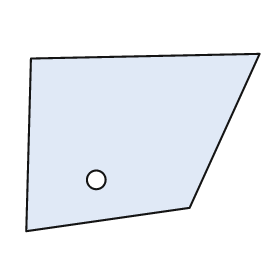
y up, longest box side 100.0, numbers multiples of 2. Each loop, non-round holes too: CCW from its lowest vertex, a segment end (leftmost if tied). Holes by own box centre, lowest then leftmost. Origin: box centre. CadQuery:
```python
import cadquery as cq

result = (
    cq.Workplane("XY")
    .moveTo(-50.0, -38.0)
    .lineTo(20.0, -28.0)
    .lineTo(50.0, 38.0)
    .lineTo(-48.0, 36.0)
    .close()
    .moveTo(-20.0, -16.0)
    .circle(4.0)
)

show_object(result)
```